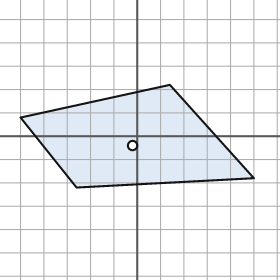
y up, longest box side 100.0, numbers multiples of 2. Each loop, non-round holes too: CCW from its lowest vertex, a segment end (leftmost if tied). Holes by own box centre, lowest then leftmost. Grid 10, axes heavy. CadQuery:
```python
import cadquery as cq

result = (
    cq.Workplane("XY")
    .moveTo(-26.0, -22.0)
    .lineTo(50.0, -18.0)
    .lineTo(14.0, 22.0)
    .lineTo(-50.0, 8.0)
    .close()
    .moveTo(-2.0, -4.0)
    .circle(2.0)
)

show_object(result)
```